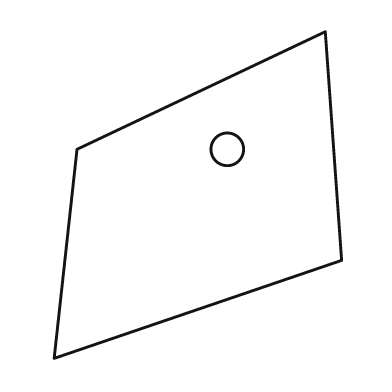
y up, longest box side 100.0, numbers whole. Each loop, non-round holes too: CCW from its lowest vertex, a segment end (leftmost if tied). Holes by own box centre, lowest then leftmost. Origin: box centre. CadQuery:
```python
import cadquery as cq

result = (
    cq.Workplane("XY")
    .moveTo(-44.0, -50.0)
    .lineTo(44.0, -20.0)
    .lineTo(39.0, 50.0)
    .lineTo(-37.0, 14.0)
    .close()
    .moveTo(9.0, 14.0)
    .circle(5.0)
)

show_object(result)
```